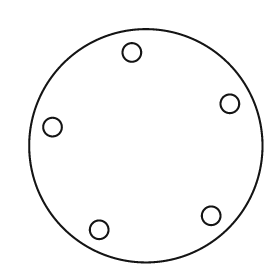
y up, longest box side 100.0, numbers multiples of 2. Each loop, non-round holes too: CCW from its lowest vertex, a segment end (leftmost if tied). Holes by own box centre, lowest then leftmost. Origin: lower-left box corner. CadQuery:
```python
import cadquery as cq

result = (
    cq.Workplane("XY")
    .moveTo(50.0, 50.0)
    .circle(50.0)
    .moveTo(30.0, 14.0)
    .circle(4.0)
    .moveTo(78.0, 20.0)
    .circle(4.0)
    .moveTo(10.0, 58.0)
    .circle(4.0)
    .moveTo(86.0, 68.0)
    .circle(4.0)
    .moveTo(44.0, 90.0)
    .circle(4.0)
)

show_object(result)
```